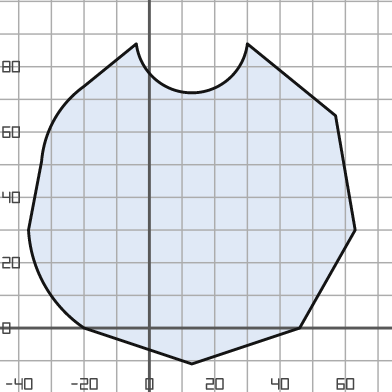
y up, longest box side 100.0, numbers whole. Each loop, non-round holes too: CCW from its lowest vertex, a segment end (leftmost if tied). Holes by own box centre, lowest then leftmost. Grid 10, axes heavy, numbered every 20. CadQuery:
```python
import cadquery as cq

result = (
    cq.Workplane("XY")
    .moveTo(13.0, -11.0)
    .lineTo(46.0, 0.0)
    .lineTo(63.0, 30.0)
    .lineTo(57.0, 65.0)
    .lineTo(30.0, 87.0)
    .threePointArc((13.0, 72.0), (-4.0, 87.0))
    .lineTo(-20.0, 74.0)
    .threePointArc((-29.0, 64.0), (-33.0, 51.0))
    .lineTo(-37.0, 30.0)
    .threePointArc((-32.0, 13.0), (-20.0, 0.0))
    .close()
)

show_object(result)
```